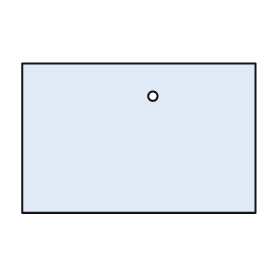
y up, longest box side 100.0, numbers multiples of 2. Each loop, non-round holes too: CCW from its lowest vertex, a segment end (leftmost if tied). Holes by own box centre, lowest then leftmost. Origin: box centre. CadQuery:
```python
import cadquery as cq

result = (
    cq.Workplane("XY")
    .moveTo(-50.0, -32.0)
    .lineTo(50.0, -32.0)
    .lineTo(50.0, 32.0)
    .lineTo(-50.0, 32.0)
    .close()
    .moveTo(6.0, 18.0)
    .circle(2.0)
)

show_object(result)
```